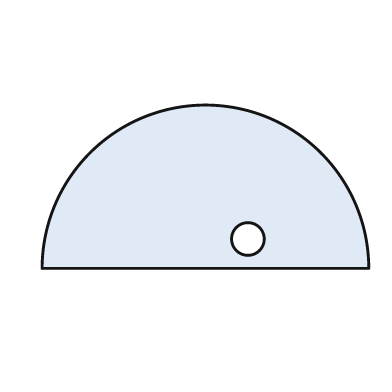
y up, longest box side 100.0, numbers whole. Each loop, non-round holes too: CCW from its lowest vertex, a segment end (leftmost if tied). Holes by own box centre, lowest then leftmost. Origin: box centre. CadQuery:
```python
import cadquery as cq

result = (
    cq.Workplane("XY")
    .moveTo(-50.0, -25.0)
    .lineTo(50.0, -25.0)
    .threePointArc((0.0, 25.0), (-50.0, -25.0))
    .close()
    .moveTo(13.0, -16.0)
    .circle(5.0)
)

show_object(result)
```